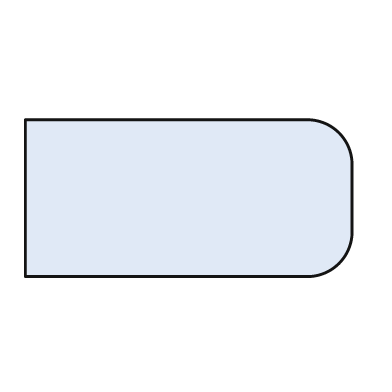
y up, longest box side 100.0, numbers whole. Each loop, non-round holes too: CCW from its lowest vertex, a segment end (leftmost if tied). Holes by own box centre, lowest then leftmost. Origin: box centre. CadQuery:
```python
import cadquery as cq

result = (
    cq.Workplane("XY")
    .moveTo(-50.0, -24.0)
    .lineTo(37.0, -24.0)
    .threePointArc((46.0, -20.0), (50.0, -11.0))
    .lineTo(50.0, 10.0)
    .threePointArc((46.0, 20.0), (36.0, 24.0))
    .lineTo(-50.0, 24.0)
    .close()
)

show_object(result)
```